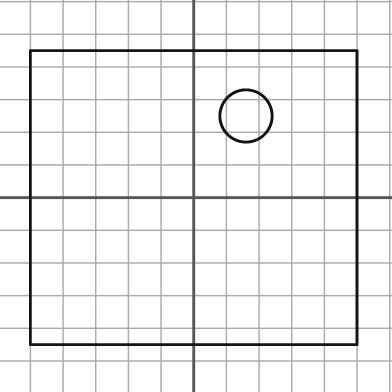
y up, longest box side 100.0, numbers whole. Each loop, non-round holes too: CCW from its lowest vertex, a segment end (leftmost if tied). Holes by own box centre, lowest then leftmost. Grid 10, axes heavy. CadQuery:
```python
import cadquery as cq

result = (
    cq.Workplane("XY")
    .moveTo(-50.0, -45.0)
    .lineTo(50.0, -45.0)
    .lineTo(50.0, 45.0)
    .lineTo(-50.0, 45.0)
    .close()
    .moveTo(16.0, 25.0)
    .circle(8.0)
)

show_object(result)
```